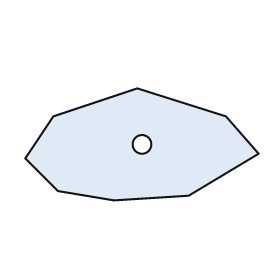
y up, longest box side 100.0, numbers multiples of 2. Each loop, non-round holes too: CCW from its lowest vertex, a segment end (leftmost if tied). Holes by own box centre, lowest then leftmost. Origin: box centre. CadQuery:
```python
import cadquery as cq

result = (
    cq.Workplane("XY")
    .moveTo(-12.0, -24.0)
    .lineTo(20.0, -22.0)
    .lineTo(50.0, -4.0)
    .lineTo(36.0, 12.0)
    .lineTo(-2.0, 24.0)
    .lineTo(-38.0, 12.0)
    .lineTo(-50.0, -6.0)
    .lineTo(-36.0, -20.0)
    .close()
    .moveTo(0.0, 0.0)
    .circle(4.0)
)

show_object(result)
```